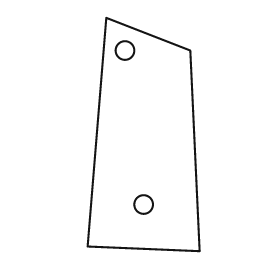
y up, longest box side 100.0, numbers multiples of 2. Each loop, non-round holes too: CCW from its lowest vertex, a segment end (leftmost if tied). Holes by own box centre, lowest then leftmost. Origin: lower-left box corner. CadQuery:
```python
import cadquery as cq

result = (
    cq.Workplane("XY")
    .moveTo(48.0, 0.0)
    .lineTo(44.0, 86.0)
    .lineTo(8.0, 100.0)
    .lineTo(0.0, 2.0)
    .close()
    .moveTo(24.0, 20.0)
    .circle(4.0)
    .moveTo(16.0, 86.0)
    .circle(4.0)
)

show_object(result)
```